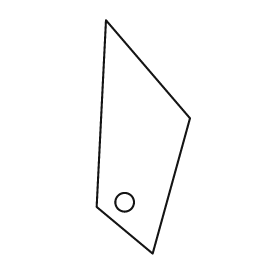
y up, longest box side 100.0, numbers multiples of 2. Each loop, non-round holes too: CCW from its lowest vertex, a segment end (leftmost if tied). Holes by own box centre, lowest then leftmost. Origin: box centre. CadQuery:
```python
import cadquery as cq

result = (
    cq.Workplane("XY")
    .moveTo(4.0, -50.0)
    .lineTo(20.0, 8.0)
    .lineTo(-16.0, 50.0)
    .lineTo(-20.0, -30.0)
    .close()
    .moveTo(-8.0, -28.0)
    .circle(4.0)
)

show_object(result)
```